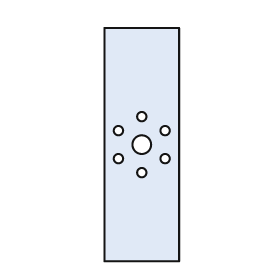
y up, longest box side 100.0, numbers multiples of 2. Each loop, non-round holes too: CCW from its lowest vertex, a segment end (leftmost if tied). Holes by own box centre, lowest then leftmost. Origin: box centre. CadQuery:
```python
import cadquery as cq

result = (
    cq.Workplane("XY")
    .moveTo(-16.0, -50.0)
    .lineTo(16.0, -50.0)
    .lineTo(16.0, 50.0)
    .lineTo(-16.0, 50.0)
    .close()
    .moveTo(0.0, -12.0)
    .circle(2.0)
    .moveTo(-10.0, -6.0)
    .circle(2.0)
    .moveTo(10.0, -6.0)
    .circle(2.0)
    .moveTo(0.0, 0.0)
    .circle(4.0)
    .moveTo(-10.0, 6.0)
    .circle(2.0)
    .moveTo(10.0, 6.0)
    .circle(2.0)
    .moveTo(0.0, 12.0)
    .circle(2.0)
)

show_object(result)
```